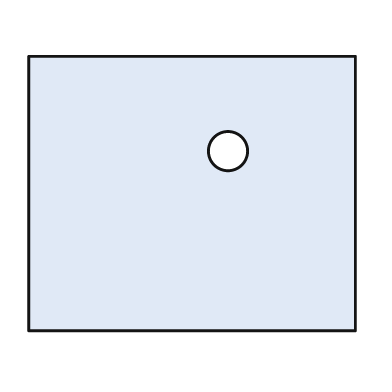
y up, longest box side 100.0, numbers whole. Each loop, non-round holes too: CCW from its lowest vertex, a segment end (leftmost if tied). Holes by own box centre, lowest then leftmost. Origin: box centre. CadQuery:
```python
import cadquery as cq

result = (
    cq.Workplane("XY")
    .moveTo(-50.0, -42.0)
    .lineTo(50.0, -42.0)
    .lineTo(50.0, 42.0)
    .lineTo(-50.0, 42.0)
    .close()
    .moveTo(11.0, 13.0)
    .circle(6.0)
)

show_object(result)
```